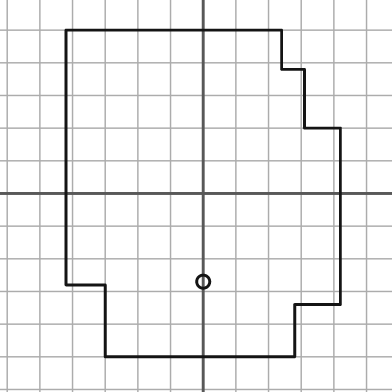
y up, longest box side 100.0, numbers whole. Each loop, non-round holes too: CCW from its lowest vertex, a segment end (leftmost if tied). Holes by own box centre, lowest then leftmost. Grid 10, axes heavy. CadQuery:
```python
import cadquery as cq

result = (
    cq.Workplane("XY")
    .moveTo(-30.0, -50.0)
    .lineTo(28.0, -50.0)
    .lineTo(28.0, -34.0)
    .lineTo(42.0, -34.0)
    .lineTo(42.0, 20.0)
    .lineTo(31.0, 20.0)
    .lineTo(31.0, 38.0)
    .lineTo(24.0, 38.0)
    .lineTo(24.0, 50.0)
    .lineTo(-42.0, 50.0)
    .lineTo(-42.0, -28.0)
    .lineTo(-30.0, -28.0)
    .close()
    .moveTo(0.0, -27.0)
    .circle(2.0)
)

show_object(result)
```